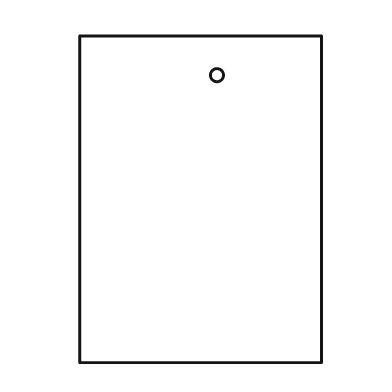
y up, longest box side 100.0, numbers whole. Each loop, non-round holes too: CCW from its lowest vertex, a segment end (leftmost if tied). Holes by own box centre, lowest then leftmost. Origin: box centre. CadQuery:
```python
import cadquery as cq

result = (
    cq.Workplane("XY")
    .moveTo(-37.0, -50.0)
    .lineTo(37.0, -50.0)
    .lineTo(37.0, 50.0)
    .lineTo(-37.0, 50.0)
    .close()
    .moveTo(5.0, 38.0)
    .circle(2.0)
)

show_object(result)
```